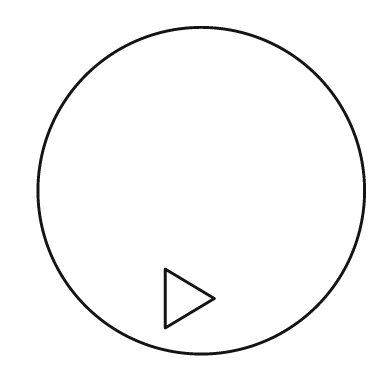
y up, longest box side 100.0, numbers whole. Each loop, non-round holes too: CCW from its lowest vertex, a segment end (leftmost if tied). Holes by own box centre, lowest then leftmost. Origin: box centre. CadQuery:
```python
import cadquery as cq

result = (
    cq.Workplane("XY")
    .moveTo(0.0, 0.0)
    .circle(50.0)
    .moveTo(-11.0, -42.0)
    .lineTo(4.0, -33.0)
    .lineTo(-11.0, -24.0)
    .close()
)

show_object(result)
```